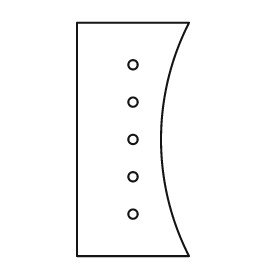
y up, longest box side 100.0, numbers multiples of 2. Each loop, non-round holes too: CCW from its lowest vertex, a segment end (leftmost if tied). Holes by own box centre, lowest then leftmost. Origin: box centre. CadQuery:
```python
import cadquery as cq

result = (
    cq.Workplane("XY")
    .moveTo(-24.0, -50.0)
    .lineTo(24.0, -50.0)
    .threePointArc((12.0, 0.0), (24.0, 50.0))
    .lineTo(-24.0, 50.0)
    .close()
    .moveTo(0.0, -32.0)
    .circle(2.0)
    .moveTo(0.0, -16.0)
    .circle(2.0)
    .moveTo(0.0, 0.0)
    .circle(2.0)
    .moveTo(0.0, 16.0)
    .circle(2.0)
    .moveTo(0.0, 32.0)
    .circle(2.0)
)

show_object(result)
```